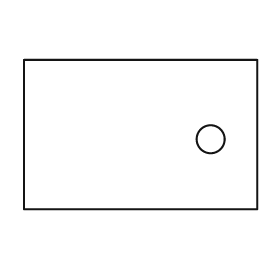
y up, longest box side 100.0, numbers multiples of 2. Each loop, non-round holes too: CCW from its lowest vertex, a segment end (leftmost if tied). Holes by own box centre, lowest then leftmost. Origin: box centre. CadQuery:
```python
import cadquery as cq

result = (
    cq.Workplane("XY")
    .moveTo(-50.0, -32.0)
    .lineTo(50.0, -32.0)
    .lineTo(50.0, 32.0)
    .lineTo(-50.0, 32.0)
    .close()
    .moveTo(30.0, -2.0)
    .circle(6.0)
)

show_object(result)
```